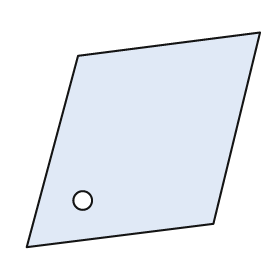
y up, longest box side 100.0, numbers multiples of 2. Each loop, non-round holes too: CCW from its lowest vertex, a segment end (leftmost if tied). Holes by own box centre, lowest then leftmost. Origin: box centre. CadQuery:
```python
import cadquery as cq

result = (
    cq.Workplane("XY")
    .moveTo(-50.0, -46.0)
    .lineTo(30.0, -36.0)
    .lineTo(50.0, 46.0)
    .lineTo(-28.0, 36.0)
    .close()
    .moveTo(-26.0, -26.0)
    .circle(4.0)
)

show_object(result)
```